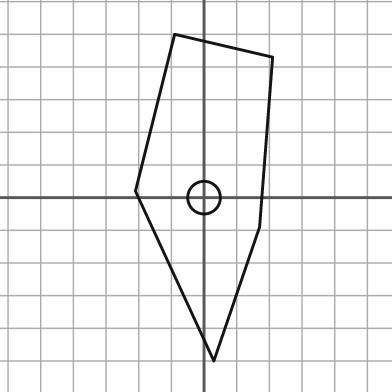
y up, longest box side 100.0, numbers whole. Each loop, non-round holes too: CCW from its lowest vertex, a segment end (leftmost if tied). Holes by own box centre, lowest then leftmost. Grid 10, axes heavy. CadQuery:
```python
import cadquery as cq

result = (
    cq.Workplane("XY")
    .moveTo(3.0, -50.0)
    .lineTo(17.0, -9.0)
    .lineTo(21.0, 43.0)
    .lineTo(-9.0, 50.0)
    .lineTo(-21.0, 2.0)
    .close()
    .moveTo(0.0, 0.0)
    .circle(5.0)
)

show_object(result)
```